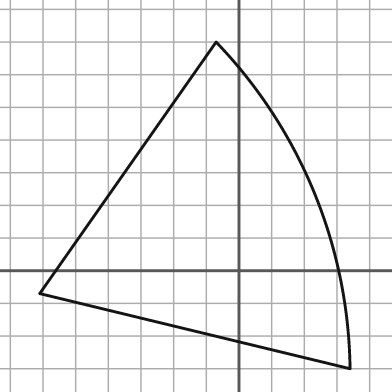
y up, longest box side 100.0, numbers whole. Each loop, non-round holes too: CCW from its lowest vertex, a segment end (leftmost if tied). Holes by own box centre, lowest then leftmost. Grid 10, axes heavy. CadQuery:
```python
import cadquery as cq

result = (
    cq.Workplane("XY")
    .moveTo(34.0, -30.0)
    .threePointArc((23.0, 24.0), (-7.0, 70.0))
    .lineTo(-61.0, -7.0)
    .close()
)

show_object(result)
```